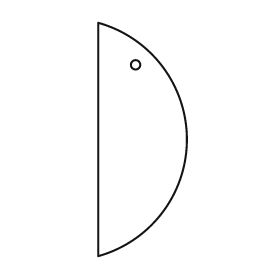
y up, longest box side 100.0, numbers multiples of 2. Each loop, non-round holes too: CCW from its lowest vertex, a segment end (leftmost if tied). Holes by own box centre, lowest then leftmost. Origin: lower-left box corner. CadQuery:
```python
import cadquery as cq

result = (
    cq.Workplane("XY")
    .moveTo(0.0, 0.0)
    .threePointArc((38.0, 50.0), (0.0, 100.0))
    .close()
    .moveTo(16.0, 82.0)
    .circle(2.0)
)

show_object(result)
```